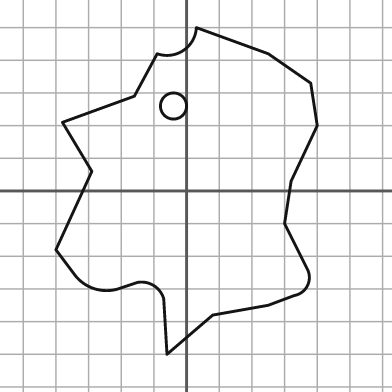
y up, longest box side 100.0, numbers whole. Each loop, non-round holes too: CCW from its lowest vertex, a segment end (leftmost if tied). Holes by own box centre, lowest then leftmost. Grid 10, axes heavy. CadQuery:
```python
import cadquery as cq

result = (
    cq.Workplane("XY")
    .moveTo(-6.0, -50.0)
    .lineTo(8.0, -38.0)
    .lineTo(25.0, -35.0)
    .lineTo(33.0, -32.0)
    .threePointArc((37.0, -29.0), (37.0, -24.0))
    .lineTo(30.0, -10.0)
    .lineTo(32.0, 3.0)
    .lineTo(40.0, 20.0)
    .lineTo(38.0, 33.0)
    .lineTo(25.0, 42.0)
    .lineTo(3.0, 50.0)
    .threePointArc((-1.0, 43.0), (-9.0, 42.0))
    .lineTo(-16.0, 29.0)
    .lineTo(-38.0, 21.0)
    .lineTo(-29.0, 6.0)
    .lineTo(-40.0, -18.0)
    .lineTo(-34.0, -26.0)
    .threePointArc((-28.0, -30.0), (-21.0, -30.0))
    .lineTo(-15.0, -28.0)
    .threePointArc((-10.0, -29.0), (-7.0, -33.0))
    .close()
    .moveTo(-4.0, 26.0)
    .circle(4.0)
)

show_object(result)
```